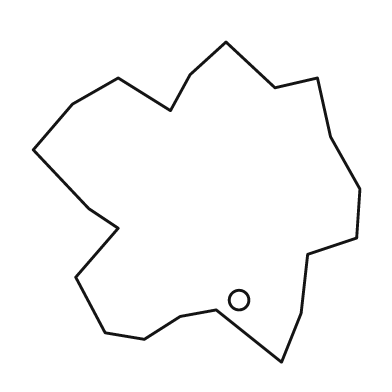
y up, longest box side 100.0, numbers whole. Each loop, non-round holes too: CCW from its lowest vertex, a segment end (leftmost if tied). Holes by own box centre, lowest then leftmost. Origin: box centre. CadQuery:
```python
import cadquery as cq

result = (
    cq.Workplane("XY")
    .moveTo(26.0, -49.0)
    .lineTo(32.0, -34.0)
    .lineTo(34.0, -16.0)
    .lineTo(49.0, -11.0)
    .lineTo(50.0, 4.0)
    .lineTo(41.0, 20.0)
    .lineTo(37.0, 38.0)
    .lineTo(24.0, 35.0)
    .lineTo(9.0, 49.0)
    .lineTo(-2.0, 39.0)
    .lineTo(-8.0, 28.0)
    .lineTo(-24.0, 38.0)
    .lineTo(-38.0, 30.0)
    .lineTo(-50.0, 16.0)
    .lineTo(-33.0, -2.0)
    .lineTo(-24.0, -8.0)
    .lineTo(-37.0, -23.0)
    .lineTo(-28.0, -40.0)
    .lineTo(-16.0, -42.0)
    .lineTo(-5.0, -35.0)
    .lineTo(6.0, -33.0)
    .close()
    .moveTo(13.0, -30.0)
    .circle(3.0)
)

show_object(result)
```